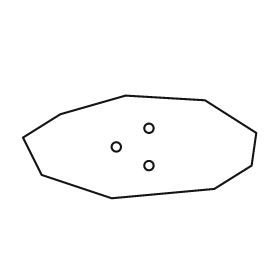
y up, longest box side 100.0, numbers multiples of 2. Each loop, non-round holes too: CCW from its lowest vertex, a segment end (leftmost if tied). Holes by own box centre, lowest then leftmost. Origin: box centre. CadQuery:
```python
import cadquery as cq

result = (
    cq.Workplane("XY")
    .moveTo(-12.0, -22.0)
    .lineTo(32.0, -18.0)
    .lineTo(48.0, -8.0)
    .lineTo(50.0, 6.0)
    .lineTo(28.0, 20.0)
    .lineTo(-6.0, 22.0)
    .lineTo(-34.0, 14.0)
    .lineTo(-50.0, 4.0)
    .lineTo(-42.0, -12.0)
    .close()
    .moveTo(4.0, -8.0)
    .circle(2.0)
    .moveTo(-10.0, 0.0)
    .circle(2.0)
    .moveTo(4.0, 8.0)
    .circle(2.0)
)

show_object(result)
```